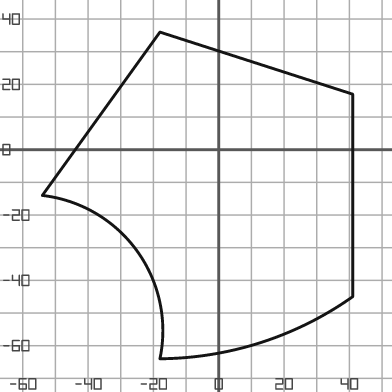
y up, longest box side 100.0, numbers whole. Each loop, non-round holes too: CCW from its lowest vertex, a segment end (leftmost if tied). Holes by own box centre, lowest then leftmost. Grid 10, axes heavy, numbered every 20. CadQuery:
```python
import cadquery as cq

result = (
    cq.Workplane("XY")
    .moveTo(-18.0, -64.0)
    .threePointArc((13.0, -59.0), (41.0, -45.0))
    .lineTo(41.0, 17.0)
    .lineTo(-18.0, 36.0)
    .lineTo(-54.0, -14.0)
    .threePointArc((-25.0, -31.0), (-18.0, -64.0))
    .close()
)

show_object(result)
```